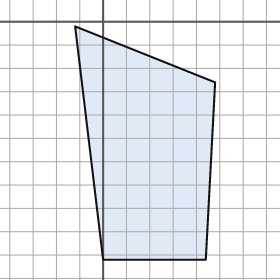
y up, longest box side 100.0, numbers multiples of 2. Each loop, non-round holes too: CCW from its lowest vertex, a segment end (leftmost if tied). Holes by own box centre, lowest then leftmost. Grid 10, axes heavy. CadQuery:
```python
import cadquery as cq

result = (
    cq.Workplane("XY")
    .moveTo(0.0, -102.0)
    .lineTo(44.0, -102.0)
    .lineTo(48.0, -26.0)
    .lineTo(-12.0, -2.0)
    .close()
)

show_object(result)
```